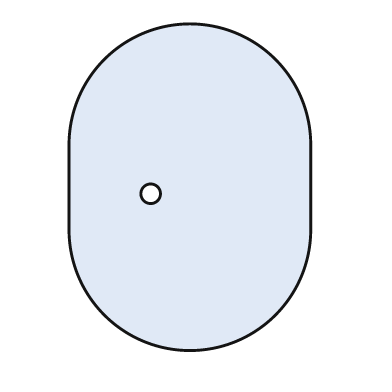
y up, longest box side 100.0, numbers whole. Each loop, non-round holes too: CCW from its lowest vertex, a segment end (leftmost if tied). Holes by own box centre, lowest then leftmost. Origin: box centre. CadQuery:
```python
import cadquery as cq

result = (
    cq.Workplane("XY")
    .moveTo(-37.0, -13.0)
    .threePointArc((0.0, -50.0), (37.0, -13.0))
    .lineTo(37.0, 13.0)
    .threePointArc((0.0, 50.0), (-37.0, 13.0))
    .close()
    .moveTo(-12.0, -2.0)
    .circle(3.0)
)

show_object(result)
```